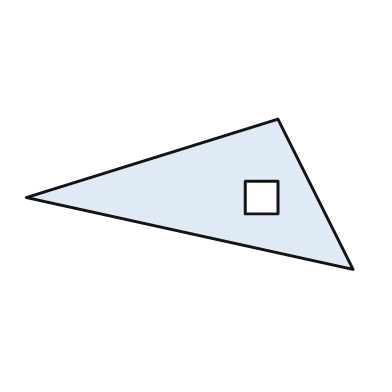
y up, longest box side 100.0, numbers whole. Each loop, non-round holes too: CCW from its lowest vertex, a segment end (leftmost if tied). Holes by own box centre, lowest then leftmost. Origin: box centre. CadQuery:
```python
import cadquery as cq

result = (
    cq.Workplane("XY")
    .moveTo(50.0, -23.0)
    .lineTo(27.0, 23.0)
    .lineTo(-50.0, -1.0)
    .close()
    .moveTo(17.0, -6.0)
    .lineTo(27.0, -6.0)
    .lineTo(27.0, 4.0)
    .lineTo(17.0, 4.0)
    .close()
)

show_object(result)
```